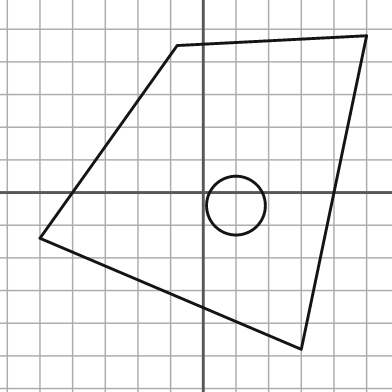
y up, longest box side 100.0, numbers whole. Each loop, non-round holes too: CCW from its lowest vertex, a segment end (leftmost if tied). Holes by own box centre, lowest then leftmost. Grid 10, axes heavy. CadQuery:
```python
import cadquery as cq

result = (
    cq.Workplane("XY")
    .moveTo(30.0, -48.0)
    .lineTo(50.0, 48.0)
    .lineTo(-8.0, 45.0)
    .lineTo(-50.0, -14.0)
    .close()
    .moveTo(10.0, -4.0)
    .circle(9.0)
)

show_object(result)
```